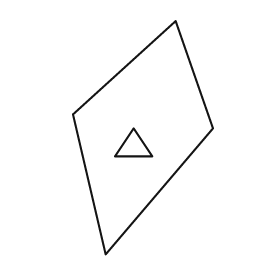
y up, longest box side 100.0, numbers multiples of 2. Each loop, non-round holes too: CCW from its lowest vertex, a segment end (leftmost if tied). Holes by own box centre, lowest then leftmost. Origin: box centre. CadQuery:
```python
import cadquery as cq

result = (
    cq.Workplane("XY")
    .moveTo(-16.0, -50.0)
    .lineTo(30.0, 4.0)
    .lineTo(14.0, 50.0)
    .lineTo(-30.0, 10.0)
    .close()
    .moveTo(-12.0, -8.0)
    .lineTo(4.0, -8.0)
    .lineTo(-4.0, 4.0)
    .close()
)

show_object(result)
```